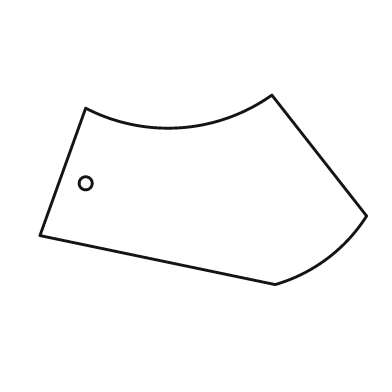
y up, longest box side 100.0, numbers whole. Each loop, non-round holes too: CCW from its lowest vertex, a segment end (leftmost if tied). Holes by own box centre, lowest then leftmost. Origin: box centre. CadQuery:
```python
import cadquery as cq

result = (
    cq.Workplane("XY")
    .moveTo(22.0, -29.0)
    .threePointArc((38.0, -21.0), (50.0, -8.0))
    .lineTo(21.0, 29.0)
    .threePointArc((-7.0, 19.0), (-36.0, 25.0))
    .lineTo(-50.0, -14.0)
    .close()
    .moveTo(-36.0, 2.0)
    .circle(2.0)
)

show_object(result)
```